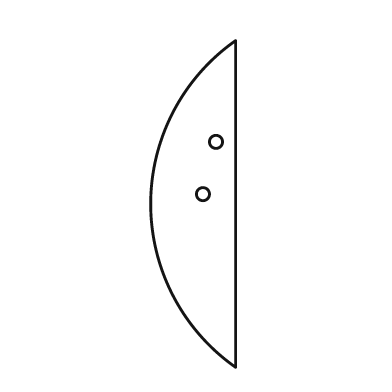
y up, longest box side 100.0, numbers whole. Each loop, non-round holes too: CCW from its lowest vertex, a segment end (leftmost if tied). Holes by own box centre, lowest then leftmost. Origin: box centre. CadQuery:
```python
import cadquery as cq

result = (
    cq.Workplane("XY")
    .moveTo(13.0, -50.0)
    .lineTo(13.0, 50.0)
    .threePointArc((-13.0, 0.0), (13.0, -50.0))
    .close()
    .moveTo(3.0, 3.0)
    .circle(2.0)
    .moveTo(7.0, 19.0)
    .circle(2.0)
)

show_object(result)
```